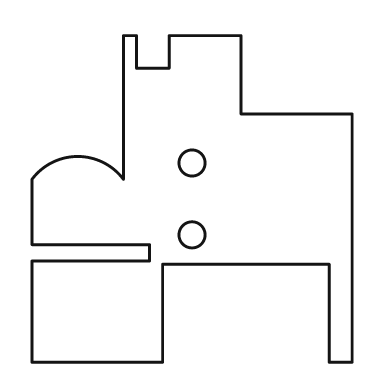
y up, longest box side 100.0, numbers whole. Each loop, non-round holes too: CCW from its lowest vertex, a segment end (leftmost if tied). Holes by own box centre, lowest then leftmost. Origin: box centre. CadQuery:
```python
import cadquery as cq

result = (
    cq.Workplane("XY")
    .moveTo(-49.0, -50.0)
    .lineTo(-9.0, -50.0)
    .lineTo(-9.0, -20.0)
    .lineTo(42.0, -20.0)
    .lineTo(42.0, -50.0)
    .lineTo(49.0, -50.0)
    .lineTo(49.0, 26.0)
    .lineTo(15.0, 26.0)
    .lineTo(15.0, 50.0)
    .lineTo(-7.0, 50.0)
    .lineTo(-7.0, 40.0)
    .lineTo(-17.0, 40.0)
    .lineTo(-17.0, 50.0)
    .lineTo(-21.0, 50.0)
    .lineTo(-21.0, 6.0)
    .threePointArc((-35.0, 13.0), (-49.0, 6.0))
    .lineTo(-49.0, -14.0)
    .lineTo(-13.0, -14.0)
    .lineTo(-13.0, -19.0)
    .lineTo(-49.0, -19.0)
    .close()
    .moveTo(0.0, -11.0)
    .circle(4.0)
    .moveTo(0.0, 11.0)
    .circle(4.0)
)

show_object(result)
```